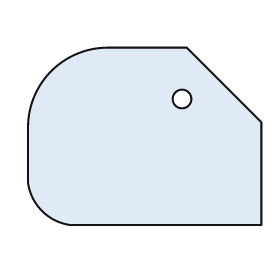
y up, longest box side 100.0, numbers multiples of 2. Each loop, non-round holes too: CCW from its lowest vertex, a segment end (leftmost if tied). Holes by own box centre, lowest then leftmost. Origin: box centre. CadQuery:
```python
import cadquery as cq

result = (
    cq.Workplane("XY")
    .moveTo(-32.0, -38.0)
    .lineTo(50.0, -38.0)
    .lineTo(50.0, 6.0)
    .lineTo(18.0, 38.0)
    .lineTo(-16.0, 38.0)
    .threePointArc((-40.0, 28.0), (-50.0, 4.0))
    .lineTo(-50.0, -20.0)
    .threePointArc((-44.0, -32.0), (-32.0, -38.0))
    .close()
    .moveTo(16.0, 16.0)
    .circle(4.0)
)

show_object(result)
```